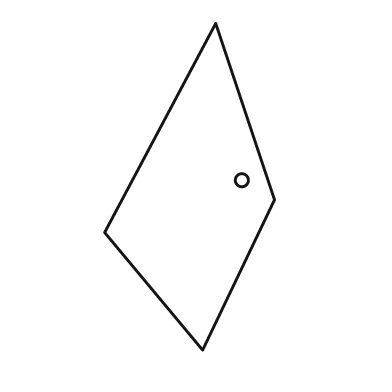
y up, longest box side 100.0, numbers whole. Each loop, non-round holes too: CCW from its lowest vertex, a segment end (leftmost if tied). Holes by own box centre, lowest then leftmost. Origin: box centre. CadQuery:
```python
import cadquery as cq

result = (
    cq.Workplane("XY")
    .moveTo(4.0, -50.0)
    .lineTo(26.0, -4.0)
    .lineTo(8.0, 50.0)
    .lineTo(-26.0, -14.0)
    .close()
    .moveTo(16.0, 2.0)
    .circle(2.0)
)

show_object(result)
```